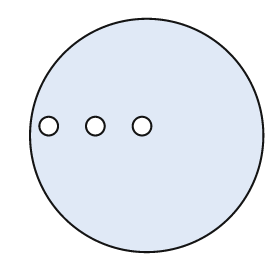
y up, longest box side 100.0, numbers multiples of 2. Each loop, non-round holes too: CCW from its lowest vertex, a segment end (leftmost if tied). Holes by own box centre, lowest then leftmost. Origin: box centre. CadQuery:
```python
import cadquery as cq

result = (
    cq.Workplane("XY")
    .moveTo(0.0, 0.0)
    .circle(50.0)
    .moveTo(-42.0, 4.0)
    .circle(4.0)
    .moveTo(-22.0, 4.0)
    .circle(4.0)
    .moveTo(-2.0, 4.0)
    .circle(4.0)
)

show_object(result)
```